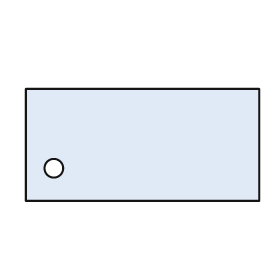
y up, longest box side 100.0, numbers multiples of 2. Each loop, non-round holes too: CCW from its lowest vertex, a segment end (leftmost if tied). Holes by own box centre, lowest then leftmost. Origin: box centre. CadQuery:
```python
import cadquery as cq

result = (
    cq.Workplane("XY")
    .moveTo(-50.0, -24.0)
    .lineTo(50.0, -24.0)
    .lineTo(50.0, 24.0)
    .lineTo(-50.0, 24.0)
    .close()
    .moveTo(-38.0, -10.0)
    .circle(4.0)
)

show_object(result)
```